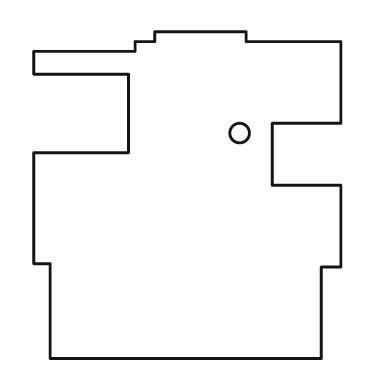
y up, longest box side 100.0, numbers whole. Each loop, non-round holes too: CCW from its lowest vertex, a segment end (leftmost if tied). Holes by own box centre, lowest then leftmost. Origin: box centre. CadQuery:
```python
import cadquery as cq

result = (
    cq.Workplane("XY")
    .moveTo(-42.0, -50.0)
    .lineTo(41.0, -50.0)
    .lineTo(41.0, -22.0)
    .lineTo(47.0, -22.0)
    .lineTo(47.0, 3.0)
    .lineTo(26.0, 3.0)
    .lineTo(26.0, 22.0)
    .lineTo(47.0, 22.0)
    .lineTo(47.0, 47.0)
    .lineTo(18.0, 47.0)
    .lineTo(18.0, 50.0)
    .lineTo(-10.0, 50.0)
    .lineTo(-10.0, 47.0)
    .lineTo(-16.0, 47.0)
    .lineTo(-16.0, 44.0)
    .lineTo(-47.0, 44.0)
    .lineTo(-47.0, 37.0)
    .lineTo(-18.0, 37.0)
    .lineTo(-18.0, 13.0)
    .lineTo(-47.0, 13.0)
    .lineTo(-47.0, -21.0)
    .lineTo(-42.0, -21.0)
    .close()
    .moveTo(16.0, 19.0)
    .circle(3.0)
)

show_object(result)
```